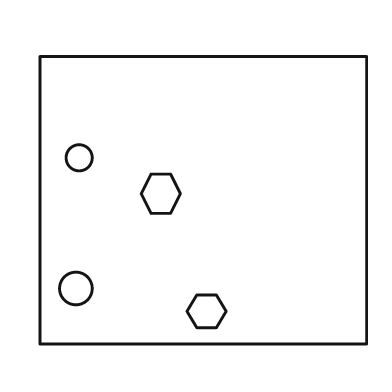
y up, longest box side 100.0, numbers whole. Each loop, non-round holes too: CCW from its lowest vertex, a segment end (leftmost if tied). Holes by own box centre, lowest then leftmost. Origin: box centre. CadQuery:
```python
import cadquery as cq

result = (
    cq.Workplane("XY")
    .moveTo(-50.0, -44.0)
    .lineTo(50.0, -44.0)
    .lineTo(50.0, 44.0)
    .lineTo(-50.0, 44.0)
    .close()
    .moveTo(-2.0, -39.0)
    .lineTo(4.0, -39.0)
    .lineTo(7.0, -34.0)
    .lineTo(4.0, -29.0)
    .lineTo(-2.0, -29.0)
    .lineTo(-5.0, -34.0)
    .close()
    .moveTo(-39.0, -27.0)
    .circle(5.0)
    .moveTo(-16.0, -4.0)
    .lineTo(-10.0, -4.0)
    .lineTo(-7.0, 2.0)
    .lineTo(-10.0, 8.0)
    .lineTo(-16.0, 8.0)
    .lineTo(-19.0, 2.0)
    .close()
    .moveTo(-38.0, 13.0)
    .circle(4.0)
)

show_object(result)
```